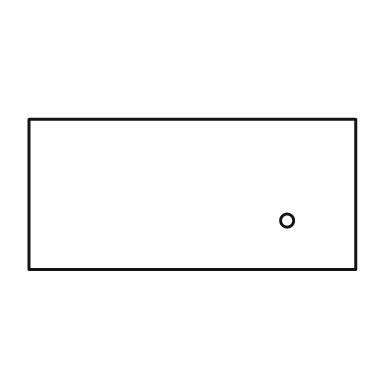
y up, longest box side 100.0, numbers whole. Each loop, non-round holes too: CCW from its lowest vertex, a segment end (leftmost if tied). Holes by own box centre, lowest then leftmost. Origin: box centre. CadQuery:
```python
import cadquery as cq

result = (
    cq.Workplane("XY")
    .moveTo(-50.0, -23.0)
    .lineTo(50.0, -23.0)
    .lineTo(50.0, 23.0)
    .lineTo(-50.0, 23.0)
    .close()
    .moveTo(29.0, -8.0)
    .circle(2.0)
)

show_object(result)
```